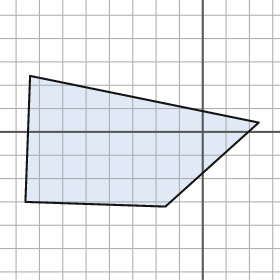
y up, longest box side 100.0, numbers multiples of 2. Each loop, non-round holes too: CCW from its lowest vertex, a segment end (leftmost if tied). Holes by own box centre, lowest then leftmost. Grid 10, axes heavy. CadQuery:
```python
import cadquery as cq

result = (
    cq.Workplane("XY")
    .moveTo(-16.0, -32.0)
    .lineTo(24.0, 4.0)
    .lineTo(-74.0, 24.0)
    .lineTo(-76.0, -30.0)
    .close()
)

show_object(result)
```